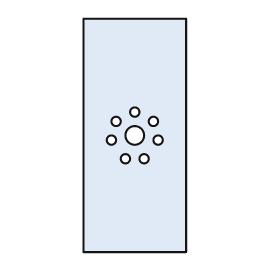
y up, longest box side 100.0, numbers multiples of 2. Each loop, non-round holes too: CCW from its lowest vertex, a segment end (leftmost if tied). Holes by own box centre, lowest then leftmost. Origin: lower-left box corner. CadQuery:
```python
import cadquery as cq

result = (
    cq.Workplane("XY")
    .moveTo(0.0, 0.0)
    .lineTo(44.0, 0.0)
    .lineTo(44.0, 100.0)
    .lineTo(0.0, 100.0)
    .close()
    .moveTo(18.0, 40.0)
    .circle(2.0)
    .moveTo(26.0, 40.0)
    .circle(2.0)
    .moveTo(12.0, 48.0)
    .circle(2.0)
    .moveTo(32.0, 48.0)
    .circle(2.0)
    .moveTo(22.0, 50.0)
    .circle(4.0)
    .moveTo(14.0, 56.0)
    .circle(2.0)
    .moveTo(30.0, 56.0)
    .circle(2.0)
    .moveTo(22.0, 60.0)
    .circle(2.0)
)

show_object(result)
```